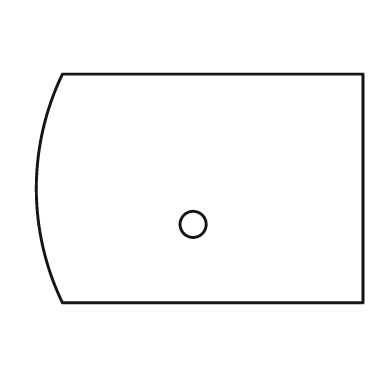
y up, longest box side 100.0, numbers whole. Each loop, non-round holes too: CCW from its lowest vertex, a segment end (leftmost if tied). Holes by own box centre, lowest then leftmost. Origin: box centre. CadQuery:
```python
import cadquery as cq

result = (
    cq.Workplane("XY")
    .moveTo(-42.0, -35.0)
    .lineTo(50.0, -35.0)
    .lineTo(50.0, 35.0)
    .lineTo(-42.0, 35.0)
    .threePointArc((-50.0, 0.0), (-42.0, -35.0))
    .close()
    .moveTo(-2.0, -11.0)
    .circle(4.0)
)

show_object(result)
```